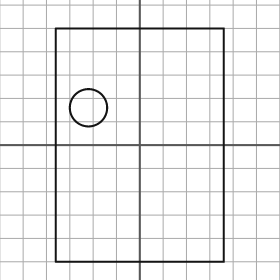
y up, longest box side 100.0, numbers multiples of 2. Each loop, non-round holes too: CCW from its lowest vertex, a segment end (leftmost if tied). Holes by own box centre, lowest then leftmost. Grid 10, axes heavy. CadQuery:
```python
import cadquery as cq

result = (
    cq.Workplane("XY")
    .moveTo(-36.0, -50.0)
    .lineTo(36.0, -50.0)
    .lineTo(36.0, 50.0)
    .lineTo(-36.0, 50.0)
    .close()
    .moveTo(-22.0, 16.0)
    .circle(8.0)
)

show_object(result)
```